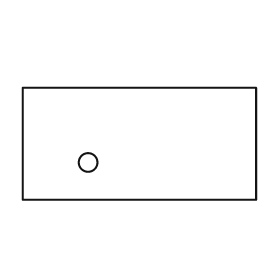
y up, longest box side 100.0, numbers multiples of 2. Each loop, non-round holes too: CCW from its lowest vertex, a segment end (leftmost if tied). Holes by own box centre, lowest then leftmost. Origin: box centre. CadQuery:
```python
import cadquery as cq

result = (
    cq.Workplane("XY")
    .moveTo(-50.0, -24.0)
    .lineTo(50.0, -24.0)
    .lineTo(50.0, 24.0)
    .lineTo(-50.0, 24.0)
    .close()
    .moveTo(-22.0, -8.0)
    .circle(4.0)
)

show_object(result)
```